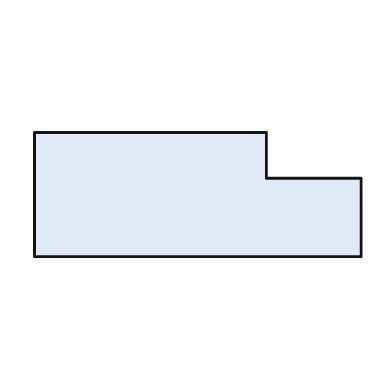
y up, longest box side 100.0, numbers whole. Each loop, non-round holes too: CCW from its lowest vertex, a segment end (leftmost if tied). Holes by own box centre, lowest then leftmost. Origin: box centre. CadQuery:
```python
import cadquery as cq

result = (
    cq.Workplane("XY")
    .moveTo(-50.0, -19.0)
    .lineTo(50.0, -19.0)
    .lineTo(50.0, 5.0)
    .lineTo(21.0, 5.0)
    .lineTo(21.0, 19.0)
    .lineTo(-50.0, 19.0)
    .close()
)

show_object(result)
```